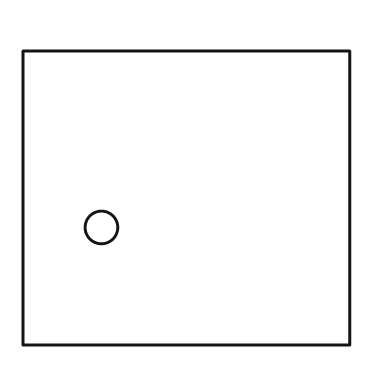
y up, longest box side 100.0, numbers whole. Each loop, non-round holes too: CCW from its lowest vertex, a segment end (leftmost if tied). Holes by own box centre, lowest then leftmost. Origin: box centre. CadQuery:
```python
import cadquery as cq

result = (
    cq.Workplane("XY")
    .moveTo(-50.0, -45.0)
    .lineTo(50.0, -45.0)
    .lineTo(50.0, 45.0)
    .lineTo(-50.0, 45.0)
    .close()
    .moveTo(-26.0, -9.0)
    .circle(5.0)
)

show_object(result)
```